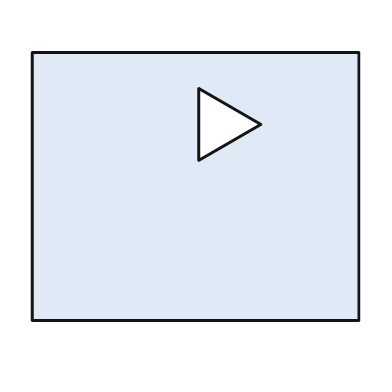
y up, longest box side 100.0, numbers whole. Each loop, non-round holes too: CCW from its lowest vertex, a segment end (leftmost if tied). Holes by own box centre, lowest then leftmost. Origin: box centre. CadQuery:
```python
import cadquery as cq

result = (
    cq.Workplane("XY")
    .moveTo(-50.0, -41.0)
    .lineTo(50.0, -41.0)
    .lineTo(50.0, 41.0)
    .lineTo(-50.0, 41.0)
    .close()
    .moveTo(1.0, 8.0)
    .lineTo(20.0, 19.0)
    .lineTo(1.0, 30.0)
    .close()
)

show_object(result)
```